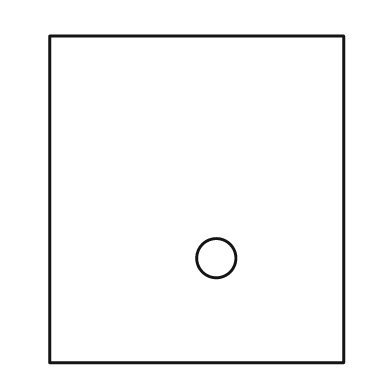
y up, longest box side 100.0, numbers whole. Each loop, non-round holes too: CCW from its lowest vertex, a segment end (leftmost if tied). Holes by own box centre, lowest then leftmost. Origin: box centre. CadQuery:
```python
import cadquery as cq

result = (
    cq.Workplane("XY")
    .moveTo(-45.0, -50.0)
    .lineTo(45.0, -50.0)
    .lineTo(45.0, 50.0)
    .lineTo(-45.0, 50.0)
    .close()
    .moveTo(6.0, -18.0)
    .circle(6.0)
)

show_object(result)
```